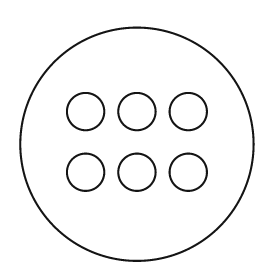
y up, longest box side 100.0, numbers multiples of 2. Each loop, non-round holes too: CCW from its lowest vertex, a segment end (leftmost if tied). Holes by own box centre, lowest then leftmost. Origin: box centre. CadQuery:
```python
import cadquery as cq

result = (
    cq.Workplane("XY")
    .moveTo(0.0, 0.0)
    .circle(50.0)
    .moveTo(-22.0, -12.0)
    .circle(8.0)
    .moveTo(0.0, -12.0)
    .circle(8.0)
    .moveTo(22.0, -12.0)
    .circle(8.0)
    .moveTo(-22.0, 14.0)
    .circle(8.0)
    .moveTo(0.0, 14.0)
    .circle(8.0)
    .moveTo(22.0, 14.0)
    .circle(8.0)
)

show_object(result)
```